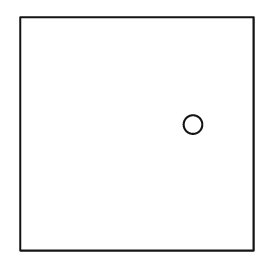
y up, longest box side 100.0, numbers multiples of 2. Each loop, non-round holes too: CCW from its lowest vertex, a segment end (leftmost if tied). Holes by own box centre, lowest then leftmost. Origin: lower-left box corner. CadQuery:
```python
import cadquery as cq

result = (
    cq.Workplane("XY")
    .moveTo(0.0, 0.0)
    .lineTo(100.0, 0.0)
    .lineTo(100.0, 100.0)
    .lineTo(0.0, 100.0)
    .close()
    .moveTo(74.0, 54.0)
    .circle(4.0)
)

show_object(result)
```